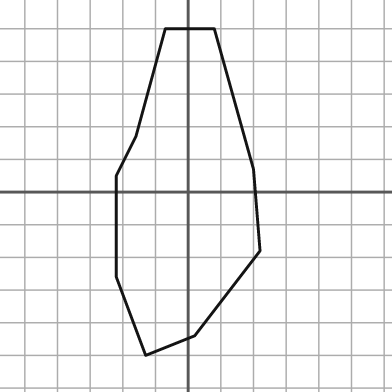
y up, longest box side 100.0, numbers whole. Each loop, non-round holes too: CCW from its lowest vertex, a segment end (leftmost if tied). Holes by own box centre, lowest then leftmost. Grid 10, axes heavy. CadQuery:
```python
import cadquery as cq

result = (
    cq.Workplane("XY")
    .moveTo(-13.0, -50.0)
    .lineTo(2.0, -44.0)
    .lineTo(22.0, -18.0)
    .lineTo(20.0, 7.0)
    .lineTo(8.0, 50.0)
    .lineTo(-7.0, 50.0)
    .lineTo(-16.0, 17.0)
    .lineTo(-22.0, 5.0)
    .lineTo(-22.0, -26.0)
    .close()
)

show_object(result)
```